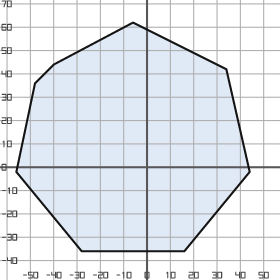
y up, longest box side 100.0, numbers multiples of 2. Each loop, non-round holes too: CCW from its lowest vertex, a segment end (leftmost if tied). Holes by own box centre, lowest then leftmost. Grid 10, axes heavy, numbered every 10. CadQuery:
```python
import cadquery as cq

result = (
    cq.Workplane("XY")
    .moveTo(-28.0, -36.0)
    .lineTo(16.0, -36.0)
    .lineTo(44.0, -2.0)
    .lineTo(34.0, 42.0)
    .lineTo(-6.0, 62.0)
    .lineTo(-40.0, 44.0)
    .lineTo(-48.0, 36.0)
    .lineTo(-56.0, -2.0)
    .close()
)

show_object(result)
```